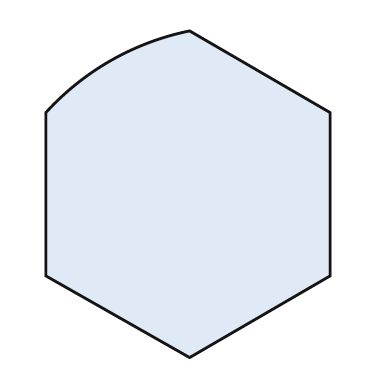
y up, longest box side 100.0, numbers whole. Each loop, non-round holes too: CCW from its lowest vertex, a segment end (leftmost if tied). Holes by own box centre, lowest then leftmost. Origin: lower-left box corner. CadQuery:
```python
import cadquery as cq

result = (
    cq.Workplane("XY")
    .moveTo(44.0, 0.0)
    .lineTo(87.0, 25.0)
    .lineTo(87.0, 75.0)
    .lineTo(44.0, 100.0)
    .threePointArc((20.0, 91.0), (0.0, 75.0))
    .lineTo(0.0, 25.0)
    .close()
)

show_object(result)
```